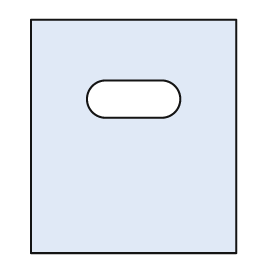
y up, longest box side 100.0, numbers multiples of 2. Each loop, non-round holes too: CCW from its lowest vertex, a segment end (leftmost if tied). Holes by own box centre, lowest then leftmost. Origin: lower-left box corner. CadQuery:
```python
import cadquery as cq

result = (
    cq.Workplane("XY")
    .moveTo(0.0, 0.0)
    .lineTo(88.0, 0.0)
    .lineTo(88.0, 100.0)
    .lineTo(0.0, 100.0)
    .close()
    .moveTo(32.0, 58.0)
    .lineTo(56.0, 58.0)
    .threePointArc((64.0, 66.0), (56.0, 74.0))
    .lineTo(32.0, 74.0)
    .threePointArc((24.0, 66.0), (32.0, 58.0))
    .close()
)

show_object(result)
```